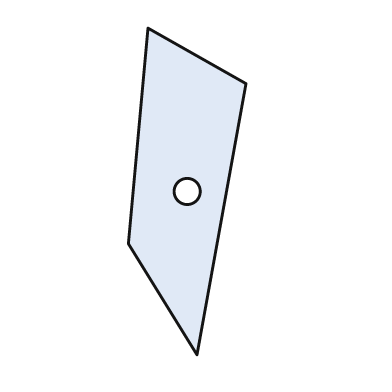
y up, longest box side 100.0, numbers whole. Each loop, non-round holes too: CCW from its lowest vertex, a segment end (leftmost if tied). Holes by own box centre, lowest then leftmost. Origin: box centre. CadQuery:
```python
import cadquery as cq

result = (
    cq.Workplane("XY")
    .moveTo(3.0, -50.0)
    .lineTo(18.0, 33.0)
    .lineTo(-12.0, 50.0)
    .lineTo(-18.0, -16.0)
    .close()
    .moveTo(0.0, 0.0)
    .circle(4.0)
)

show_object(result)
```